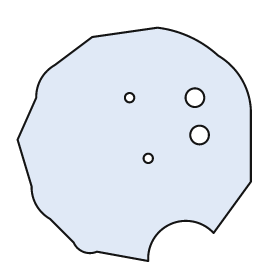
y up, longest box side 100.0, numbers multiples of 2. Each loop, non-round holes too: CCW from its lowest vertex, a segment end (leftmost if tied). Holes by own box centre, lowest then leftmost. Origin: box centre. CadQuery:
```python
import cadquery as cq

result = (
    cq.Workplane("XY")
    .moveTo(6.0, -50.0)
    .threePointArc((16.0, -34.0), (34.0, -38.0))
    .lineTo(50.0, -16.0)
    .lineTo(50.0, 14.0)
    .threePointArc((46.0, 28.0), (36.0, 38.0))
    .threePointArc((24.0, 46.0), (10.0, 50.0))
    .lineTo(-18.0, 46.0)
    .lineTo(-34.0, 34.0)
    .threePointArc((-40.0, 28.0), (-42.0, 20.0))
    .lineTo(-50.0, 2.0)
    .lineTo(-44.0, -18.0)
    .threePointArc((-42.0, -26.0), (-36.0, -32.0))
    .lineTo(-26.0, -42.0)
    .threePointArc((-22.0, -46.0), (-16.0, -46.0))
    .close()
    .moveTo(6.0, -6.0)
    .circle(2.0)
    .moveTo(28.0, 4.0)
    .circle(4.0)
    .moveTo(-2.0, 20.0)
    .circle(2.0)
    .moveTo(26.0, 20.0)
    .circle(4.0)
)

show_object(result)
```